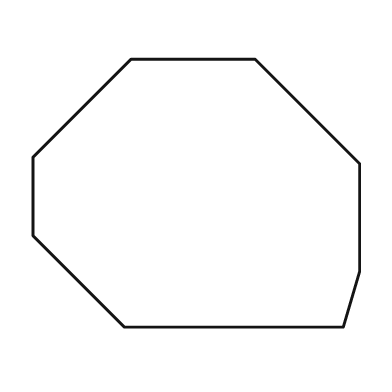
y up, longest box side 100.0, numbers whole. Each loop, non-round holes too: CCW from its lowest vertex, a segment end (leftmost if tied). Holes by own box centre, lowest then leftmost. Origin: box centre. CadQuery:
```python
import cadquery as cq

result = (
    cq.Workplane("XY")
    .moveTo(-22.0, -41.0)
    .lineTo(45.0, -41.0)
    .lineTo(50.0, -24.0)
    .lineTo(50.0, 9.0)
    .lineTo(18.0, 41.0)
    .lineTo(-20.0, 41.0)
    .lineTo(-50.0, 11.0)
    .lineTo(-50.0, -13.0)
    .close()
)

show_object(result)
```